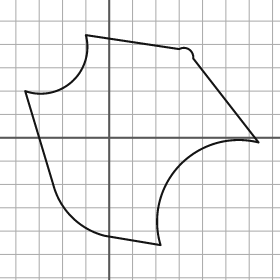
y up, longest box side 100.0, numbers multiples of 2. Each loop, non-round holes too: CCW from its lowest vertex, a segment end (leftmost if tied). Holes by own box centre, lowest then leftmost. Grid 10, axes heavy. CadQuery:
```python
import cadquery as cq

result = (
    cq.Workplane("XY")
    .moveTo(22.0, -46.0)
    .threePointArc((30.0, -12.0), (64.0, -2.0))
    .lineTo(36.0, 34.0)
    .threePointArc((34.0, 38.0), (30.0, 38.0))
    .lineTo(-10.0, 44.0)
    .threePointArc((-16.0, 24.0), (-36.0, 20.0))
    .lineTo(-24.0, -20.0)
    .threePointArc((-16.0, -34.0), (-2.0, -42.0))
    .close()
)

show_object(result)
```